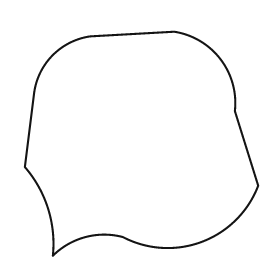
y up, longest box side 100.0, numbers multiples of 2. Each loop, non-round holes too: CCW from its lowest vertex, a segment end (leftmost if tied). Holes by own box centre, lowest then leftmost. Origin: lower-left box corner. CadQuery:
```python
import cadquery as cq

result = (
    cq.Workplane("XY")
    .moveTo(12.0, 0.0)
    .threePointArc((26.0, 8.0), (42.0, 8.0))
    .threePointArc((76.0, 6.0), (100.0, 30.0))
    .lineTo(90.0, 62.0)
    .threePointArc((84.0, 84.0), (64.0, 96.0))
    .lineTo(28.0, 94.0)
    .threePointArc((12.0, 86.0), (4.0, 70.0))
    .lineTo(0.0, 38.0)
    .threePointArc((10.0, 20.0), (12.0, 0.0))
    .close()
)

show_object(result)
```